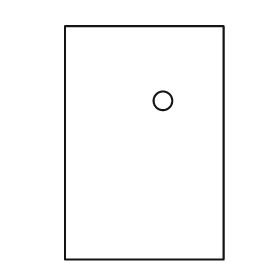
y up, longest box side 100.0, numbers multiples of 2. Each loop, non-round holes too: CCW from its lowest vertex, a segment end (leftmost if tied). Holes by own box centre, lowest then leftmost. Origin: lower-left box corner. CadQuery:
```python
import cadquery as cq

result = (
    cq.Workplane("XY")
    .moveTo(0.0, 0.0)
    .lineTo(68.0, 0.0)
    .lineTo(68.0, 100.0)
    .lineTo(0.0, 100.0)
    .close()
    .moveTo(42.0, 68.0)
    .circle(4.0)
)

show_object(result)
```